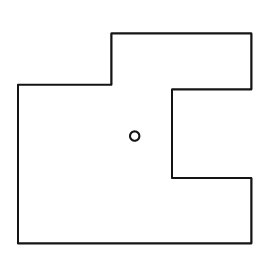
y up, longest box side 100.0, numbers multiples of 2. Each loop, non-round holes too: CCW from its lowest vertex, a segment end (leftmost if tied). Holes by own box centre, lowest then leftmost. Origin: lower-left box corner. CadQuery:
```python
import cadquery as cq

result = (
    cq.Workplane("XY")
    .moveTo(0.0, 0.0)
    .lineTo(100.0, 0.0)
    .lineTo(100.0, 28.0)
    .lineTo(66.0, 28.0)
    .lineTo(66.0, 66.0)
    .lineTo(100.0, 66.0)
    .lineTo(100.0, 90.0)
    .lineTo(40.0, 90.0)
    .lineTo(40.0, 68.0)
    .lineTo(0.0, 68.0)
    .close()
    .moveTo(50.0, 46.0)
    .circle(2.0)
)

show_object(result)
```